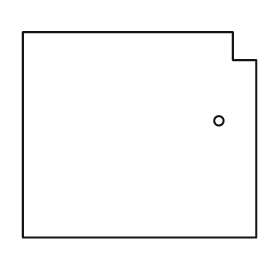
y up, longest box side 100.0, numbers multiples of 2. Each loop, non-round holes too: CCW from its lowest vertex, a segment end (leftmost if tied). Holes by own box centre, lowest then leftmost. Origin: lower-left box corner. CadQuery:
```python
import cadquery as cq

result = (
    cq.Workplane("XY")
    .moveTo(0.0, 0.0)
    .lineTo(100.0, 0.0)
    .lineTo(100.0, 76.0)
    .lineTo(90.0, 76.0)
    .lineTo(90.0, 88.0)
    .lineTo(0.0, 88.0)
    .close()
    .moveTo(84.0, 50.0)
    .circle(2.0)
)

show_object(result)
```